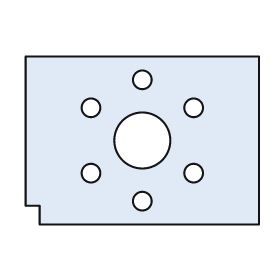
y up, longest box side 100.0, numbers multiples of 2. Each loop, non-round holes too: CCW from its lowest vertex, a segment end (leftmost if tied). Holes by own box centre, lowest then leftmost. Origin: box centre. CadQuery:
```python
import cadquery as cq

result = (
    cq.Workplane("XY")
    .moveTo(-44.0, -36.0)
    .lineTo(50.0, -36.0)
    .lineTo(50.0, 36.0)
    .lineTo(-50.0, 36.0)
    .lineTo(-50.0, -28.0)
    .lineTo(-44.0, -28.0)
    .close()
    .moveTo(0.0, -26.0)
    .circle(4.0)
    .moveTo(-22.0, -14.0)
    .circle(4.0)
    .moveTo(22.0, -14.0)
    .circle(4.0)
    .moveTo(0.0, 0.0)
    .circle(12.0)
    .moveTo(-22.0, 14.0)
    .circle(4.0)
    .moveTo(22.0, 14.0)
    .circle(4.0)
    .moveTo(0.0, 26.0)
    .circle(4.0)
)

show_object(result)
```